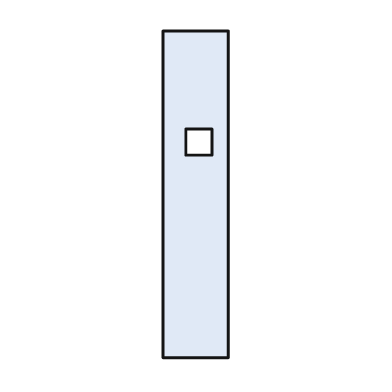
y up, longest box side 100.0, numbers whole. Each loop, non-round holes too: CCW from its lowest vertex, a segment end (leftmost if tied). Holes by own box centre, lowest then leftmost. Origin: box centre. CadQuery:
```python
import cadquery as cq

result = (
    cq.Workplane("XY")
    .moveTo(-10.0, -50.0)
    .lineTo(10.0, -50.0)
    .lineTo(10.0, 50.0)
    .lineTo(-10.0, 50.0)
    .close()
    .moveTo(-3.0, 12.0)
    .lineTo(5.0, 12.0)
    .lineTo(5.0, 20.0)
    .lineTo(-3.0, 20.0)
    .close()
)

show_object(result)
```